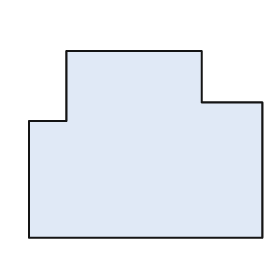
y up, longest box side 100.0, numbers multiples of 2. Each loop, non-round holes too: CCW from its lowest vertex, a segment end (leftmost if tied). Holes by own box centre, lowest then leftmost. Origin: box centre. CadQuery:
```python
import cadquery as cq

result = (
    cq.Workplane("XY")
    .moveTo(-50.0, -40.0)
    .lineTo(50.0, -40.0)
    .lineTo(50.0, 18.0)
    .lineTo(24.0, 18.0)
    .lineTo(24.0, 40.0)
    .lineTo(-34.0, 40.0)
    .lineTo(-34.0, 10.0)
    .lineTo(-50.0, 10.0)
    .close()
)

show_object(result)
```